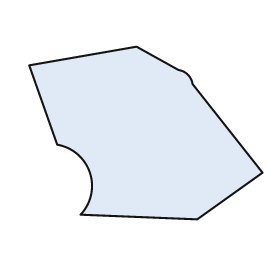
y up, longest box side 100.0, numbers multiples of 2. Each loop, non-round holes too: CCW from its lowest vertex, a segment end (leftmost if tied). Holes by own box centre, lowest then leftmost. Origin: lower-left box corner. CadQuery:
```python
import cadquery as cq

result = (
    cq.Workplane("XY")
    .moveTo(72.0, 0.0)
    .lineTo(100.0, 20.0)
    .lineTo(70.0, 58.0)
    .threePointArc((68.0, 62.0), (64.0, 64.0))
    .lineTo(46.0, 74.0)
    .lineTo(0.0, 66.0)
    .lineTo(12.0, 32.0)
    .threePointArc((26.0, 20.0), (22.0, 2.0))
    .close()
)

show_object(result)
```